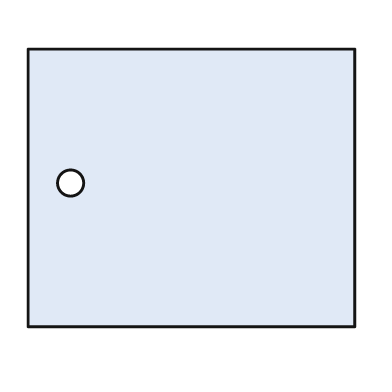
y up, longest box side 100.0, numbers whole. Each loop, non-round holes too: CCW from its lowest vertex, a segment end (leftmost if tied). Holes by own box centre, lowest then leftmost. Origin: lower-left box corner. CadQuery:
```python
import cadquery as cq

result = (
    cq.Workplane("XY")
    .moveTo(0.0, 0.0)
    .lineTo(100.0, 0.0)
    .lineTo(100.0, 85.0)
    .lineTo(0.0, 85.0)
    .close()
    .moveTo(13.0, 44.0)
    .circle(4.0)
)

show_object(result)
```